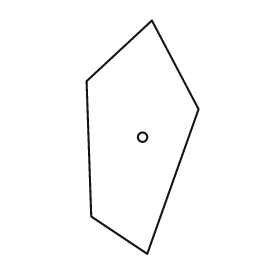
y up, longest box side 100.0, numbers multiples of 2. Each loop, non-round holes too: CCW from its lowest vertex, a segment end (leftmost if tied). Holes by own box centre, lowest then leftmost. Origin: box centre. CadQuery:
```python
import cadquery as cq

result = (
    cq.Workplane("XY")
    .moveTo(2.0, -50.0)
    .lineTo(24.0, 12.0)
    .lineTo(4.0, 50.0)
    .lineTo(-24.0, 24.0)
    .lineTo(-22.0, -34.0)
    .close()
    .moveTo(0.0, 0.0)
    .circle(2.0)
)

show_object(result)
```